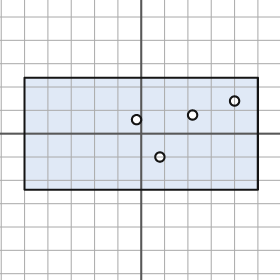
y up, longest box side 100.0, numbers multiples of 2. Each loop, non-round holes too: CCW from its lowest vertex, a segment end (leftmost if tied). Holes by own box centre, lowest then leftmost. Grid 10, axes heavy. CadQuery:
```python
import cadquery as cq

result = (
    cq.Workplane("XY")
    .moveTo(-50.0, -24.0)
    .lineTo(50.0, -24.0)
    .lineTo(50.0, 24.0)
    .lineTo(-50.0, 24.0)
    .close()
    .moveTo(8.0, -10.0)
    .circle(2.0)
    .moveTo(-2.0, 6.0)
    .circle(2.0)
    .moveTo(22.0, 8.0)
    .circle(2.0)
    .moveTo(40.0, 14.0)
    .circle(2.0)
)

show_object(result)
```